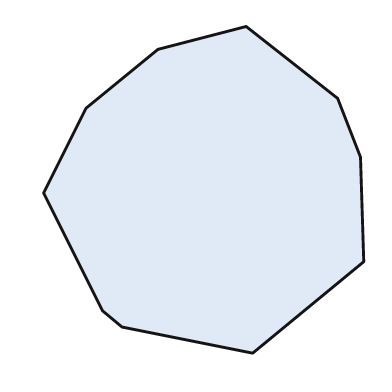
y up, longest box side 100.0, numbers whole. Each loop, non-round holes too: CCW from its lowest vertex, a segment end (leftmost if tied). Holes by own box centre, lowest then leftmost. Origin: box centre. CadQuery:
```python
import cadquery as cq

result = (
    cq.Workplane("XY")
    .moveTo(15.0, -50.0)
    .lineTo(49.0, -22.0)
    .lineTo(48.0, 10.0)
    .lineTo(41.0, 28.0)
    .lineTo(13.0, 50.0)
    .lineTo(-14.0, 43.0)
    .lineTo(-36.0, 25.0)
    .lineTo(-49.0, -1.0)
    .lineTo(-31.0, -37.0)
    .lineTo(-25.0, -42.0)
    .close()
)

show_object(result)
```